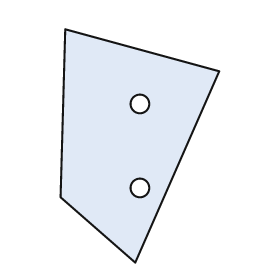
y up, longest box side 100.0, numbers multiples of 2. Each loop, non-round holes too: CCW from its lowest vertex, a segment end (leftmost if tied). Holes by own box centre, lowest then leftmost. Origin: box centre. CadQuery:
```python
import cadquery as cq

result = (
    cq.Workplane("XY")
    .moveTo(-2.0, -50.0)
    .lineTo(34.0, 32.0)
    .lineTo(-32.0, 50.0)
    .lineTo(-34.0, -22.0)
    .close()
    .moveTo(0.0, -18.0)
    .circle(4.0)
    .moveTo(0.0, 18.0)
    .circle(4.0)
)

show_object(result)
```